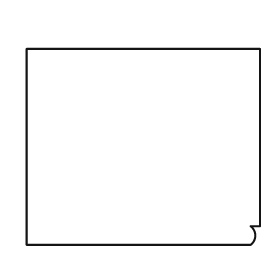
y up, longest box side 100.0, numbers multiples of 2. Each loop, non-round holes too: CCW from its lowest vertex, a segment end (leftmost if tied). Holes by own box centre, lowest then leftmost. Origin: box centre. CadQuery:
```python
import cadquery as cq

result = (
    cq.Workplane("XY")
    .moveTo(-50.0, -42.0)
    .lineTo(46.0, -42.0)
    .threePointArc((48.0, -38.0), (46.0, -34.0))
    .lineTo(50.0, -34.0)
    .lineTo(50.0, 42.0)
    .lineTo(-50.0, 42.0)
    .close()
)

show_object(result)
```